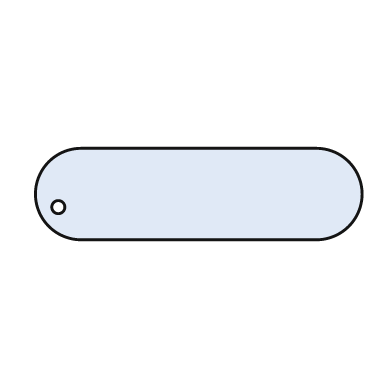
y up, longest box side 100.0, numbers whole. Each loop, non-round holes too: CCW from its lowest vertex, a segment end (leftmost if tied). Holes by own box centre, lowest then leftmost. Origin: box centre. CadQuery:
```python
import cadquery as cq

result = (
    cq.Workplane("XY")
    .moveTo(-36.0, -14.0)
    .lineTo(36.0, -14.0)
    .threePointArc((50.0, 0.0), (36.0, 14.0))
    .lineTo(-36.0, 14.0)
    .threePointArc((-50.0, 0.0), (-36.0, -14.0))
    .close()
    .moveTo(-43.0, -4.0)
    .circle(2.0)
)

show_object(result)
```